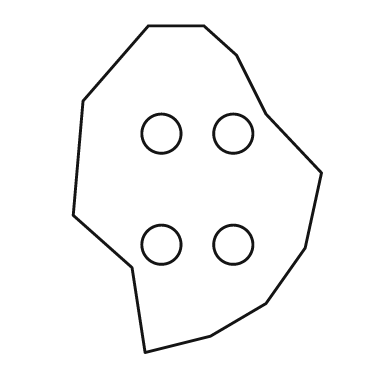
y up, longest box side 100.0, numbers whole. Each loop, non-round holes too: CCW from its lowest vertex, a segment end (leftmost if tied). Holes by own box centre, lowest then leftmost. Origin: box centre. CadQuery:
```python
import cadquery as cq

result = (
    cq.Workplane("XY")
    .moveTo(-16.0, -50.0)
    .lineTo(4.0, -45.0)
    .lineTo(21.0, -35.0)
    .lineTo(33.0, -18.0)
    .lineTo(38.0, 5.0)
    .lineTo(21.0, 23.0)
    .lineTo(12.0, 41.0)
    .lineTo(2.0, 50.0)
    .lineTo(-15.0, 50.0)
    .lineTo(-35.0, 27.0)
    .lineTo(-38.0, -8.0)
    .lineTo(-20.0, -24.0)
    .close()
    .moveTo(-11.0, -17.0)
    .circle(6.0)
    .moveTo(11.0, -17.0)
    .circle(6.0)
    .moveTo(-11.0, 17.0)
    .circle(6.0)
    .moveTo(11.0, 17.0)
    .circle(6.0)
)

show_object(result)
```